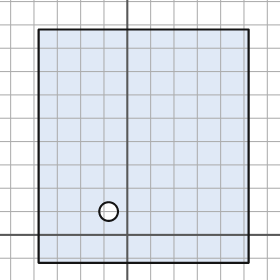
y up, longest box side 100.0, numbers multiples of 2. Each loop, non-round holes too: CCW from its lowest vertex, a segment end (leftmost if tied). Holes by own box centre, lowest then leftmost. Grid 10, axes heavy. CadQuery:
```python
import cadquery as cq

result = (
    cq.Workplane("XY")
    .moveTo(-38.0, -12.0)
    .lineTo(52.0, -12.0)
    .lineTo(52.0, 88.0)
    .lineTo(-38.0, 88.0)
    .close()
    .moveTo(-8.0, 10.0)
    .circle(4.0)
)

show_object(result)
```